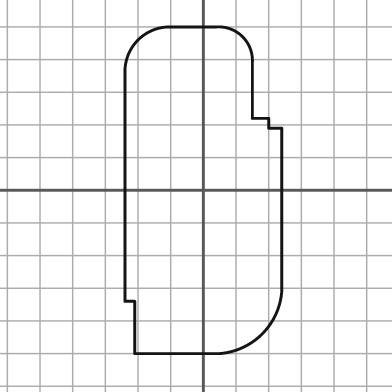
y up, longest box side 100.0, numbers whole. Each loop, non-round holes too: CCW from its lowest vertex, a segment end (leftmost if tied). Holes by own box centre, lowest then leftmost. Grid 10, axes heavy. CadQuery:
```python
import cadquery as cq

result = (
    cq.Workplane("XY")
    .moveTo(-21.0, -50.0)
    .lineTo(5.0, -50.0)
    .threePointArc((18.0, -44.0), (24.0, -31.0))
    .lineTo(24.0, 19.0)
    .lineTo(20.0, 19.0)
    .lineTo(20.0, 22.0)
    .lineTo(15.0, 22.0)
    .lineTo(15.0, 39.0)
    .threePointArc((12.0, 47.0), (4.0, 50.0))
    .lineTo(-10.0, 50.0)
    .threePointArc((-20.0, 46.0), (-24.0, 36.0))
    .lineTo(-24.0, -34.0)
    .lineTo(-21.0, -34.0)
    .close()
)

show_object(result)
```